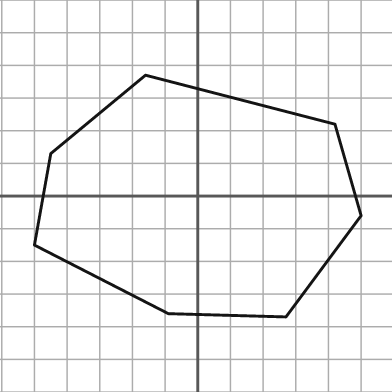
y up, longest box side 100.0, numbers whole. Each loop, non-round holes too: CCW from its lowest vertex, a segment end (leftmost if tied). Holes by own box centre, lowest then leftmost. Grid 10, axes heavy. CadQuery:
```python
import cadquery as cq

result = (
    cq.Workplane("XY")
    .moveTo(27.0, -37.0)
    .lineTo(50.0, -6.0)
    .lineTo(42.0, 22.0)
    .lineTo(-16.0, 37.0)
    .lineTo(-45.0, 13.0)
    .lineTo(-50.0, -15.0)
    .lineTo(-9.0, -36.0)
    .close()
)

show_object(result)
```